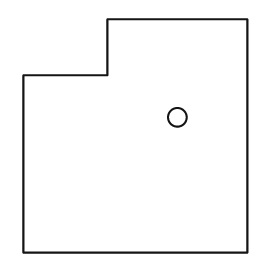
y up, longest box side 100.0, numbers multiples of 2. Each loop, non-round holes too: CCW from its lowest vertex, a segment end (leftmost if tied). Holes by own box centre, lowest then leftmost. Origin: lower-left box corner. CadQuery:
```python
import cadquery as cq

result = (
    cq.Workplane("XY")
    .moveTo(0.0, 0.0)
    .lineTo(96.0, 0.0)
    .lineTo(96.0, 100.0)
    .lineTo(36.0, 100.0)
    .lineTo(36.0, 76.0)
    .lineTo(0.0, 76.0)
    .close()
    .moveTo(66.0, 58.0)
    .circle(4.0)
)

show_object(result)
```